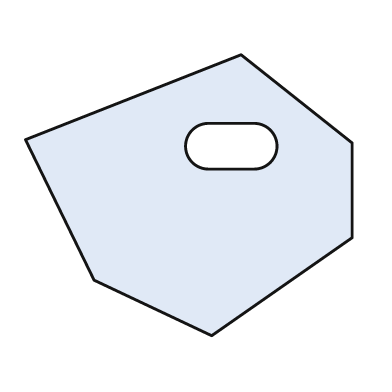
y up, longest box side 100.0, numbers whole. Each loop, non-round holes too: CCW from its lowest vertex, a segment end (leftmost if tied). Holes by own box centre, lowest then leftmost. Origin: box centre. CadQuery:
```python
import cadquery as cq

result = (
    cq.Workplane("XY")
    .moveTo(7.0, -43.0)
    .lineTo(50.0, -13.0)
    .lineTo(50.0, 16.0)
    .lineTo(16.0, 43.0)
    .lineTo(-50.0, 17.0)
    .lineTo(-29.0, -26.0)
    .close()
    .moveTo(6.0, 8.0)
    .lineTo(20.0, 8.0)
    .threePointArc((27.0, 15.0), (20.0, 22.0))
    .lineTo(6.0, 22.0)
    .threePointArc((-1.0, 15.0), (6.0, 8.0))
    .close()
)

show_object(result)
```